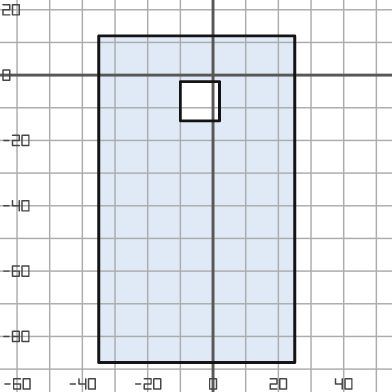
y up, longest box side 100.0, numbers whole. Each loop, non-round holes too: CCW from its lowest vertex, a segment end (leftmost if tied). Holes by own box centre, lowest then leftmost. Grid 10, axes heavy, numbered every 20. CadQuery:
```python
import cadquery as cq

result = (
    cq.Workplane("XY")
    .moveTo(-35.0, -88.0)
    .lineTo(25.0, -88.0)
    .lineTo(25.0, 12.0)
    .lineTo(-35.0, 12.0)
    .close()
    .moveTo(-10.0, -14.0)
    .lineTo(2.0, -14.0)
    .lineTo(2.0, -2.0)
    .lineTo(-10.0, -2.0)
    .close()
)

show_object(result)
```